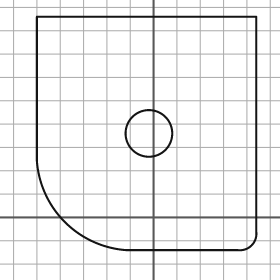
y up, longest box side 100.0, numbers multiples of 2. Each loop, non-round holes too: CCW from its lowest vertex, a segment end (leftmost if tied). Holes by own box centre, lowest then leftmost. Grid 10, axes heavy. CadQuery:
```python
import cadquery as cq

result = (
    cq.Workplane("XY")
    .moveTo(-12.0, -14.0)
    .lineTo(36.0, -14.0)
    .threePointArc((42.0, -12.0), (44.0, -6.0))
    .lineTo(44.0, 86.0)
    .lineTo(-50.0, 86.0)
    .lineTo(-50.0, 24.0)
    .threePointArc((-38.0, -2.0), (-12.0, -14.0))
    .close()
    .moveTo(-2.0, 36.0)
    .circle(10.0)
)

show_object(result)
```